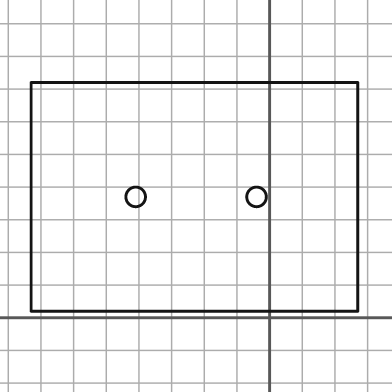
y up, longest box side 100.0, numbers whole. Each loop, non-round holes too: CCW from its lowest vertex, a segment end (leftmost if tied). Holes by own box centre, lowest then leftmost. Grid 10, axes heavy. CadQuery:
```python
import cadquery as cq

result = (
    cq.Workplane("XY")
    .moveTo(-73.0, 2.0)
    .lineTo(27.0, 2.0)
    .lineTo(27.0, 72.0)
    .lineTo(-73.0, 72.0)
    .close()
    .moveTo(-41.0, 37.0)
    .circle(3.0)
    .moveTo(-4.0, 37.0)
    .circle(3.0)
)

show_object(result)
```